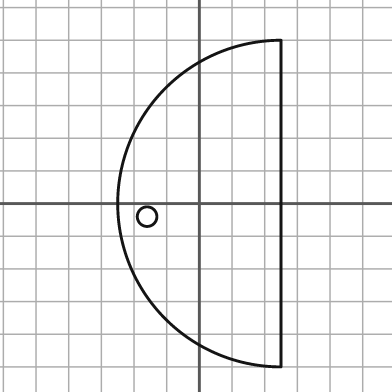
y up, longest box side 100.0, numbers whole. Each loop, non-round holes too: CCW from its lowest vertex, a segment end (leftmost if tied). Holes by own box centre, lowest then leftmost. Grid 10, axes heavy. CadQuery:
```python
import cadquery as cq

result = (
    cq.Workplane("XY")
    .moveTo(25.0, -50.0)
    .lineTo(25.0, 50.0)
    .threePointArc((-25.0, 0.0), (25.0, -50.0))
    .close()
    .moveTo(-16.0, -4.0)
    .circle(3.0)
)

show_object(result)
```